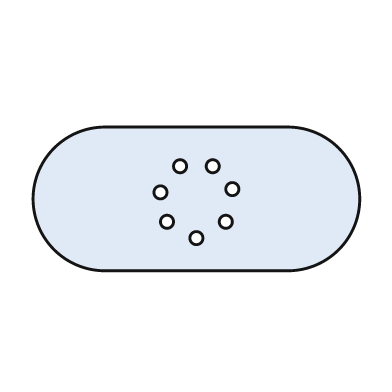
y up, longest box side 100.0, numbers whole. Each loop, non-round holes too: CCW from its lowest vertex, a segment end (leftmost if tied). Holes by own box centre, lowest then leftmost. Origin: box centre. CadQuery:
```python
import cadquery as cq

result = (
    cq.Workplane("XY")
    .moveTo(-28.0, -22.0)
    .lineTo(28.0, -22.0)
    .threePointArc((50.0, 0.0), (28.0, 22.0))
    .lineTo(-28.0, 22.0)
    .threePointArc((-50.0, 0.0), (-28.0, -22.0))
    .close()
    .moveTo(0.0, -12.0)
    .circle(2.0)
    .moveTo(-9.0, -7.0)
    .circle(2.0)
    .moveTo(9.0, -7.0)
    .circle(2.0)
    .moveTo(-11.0, 2.0)
    .circle(2.0)
    .moveTo(11.0, 3.0)
    .circle(2.0)
    .moveTo(-5.0, 10.0)
    .circle(2.0)
    .moveTo(5.0, 10.0)
    .circle(2.0)
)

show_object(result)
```